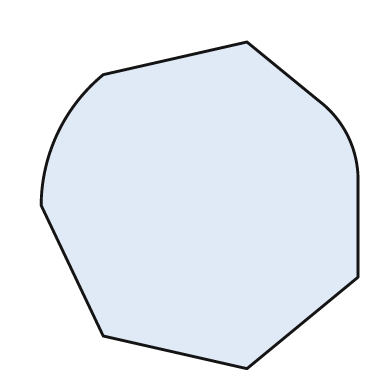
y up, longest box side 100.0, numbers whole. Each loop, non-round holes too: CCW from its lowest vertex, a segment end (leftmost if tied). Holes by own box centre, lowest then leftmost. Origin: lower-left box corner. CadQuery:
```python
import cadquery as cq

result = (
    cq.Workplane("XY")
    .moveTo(63.0, 0.0)
    .lineTo(97.0, 28.0)
    .lineTo(97.0, 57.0)
    .threePointArc((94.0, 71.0), (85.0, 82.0))
    .lineTo(63.0, 100.0)
    .lineTo(19.0, 90.0)
    .threePointArc((5.0, 72.0), (0.0, 50.0))
    .lineTo(19.0, 10.0)
    .close()
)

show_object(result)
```